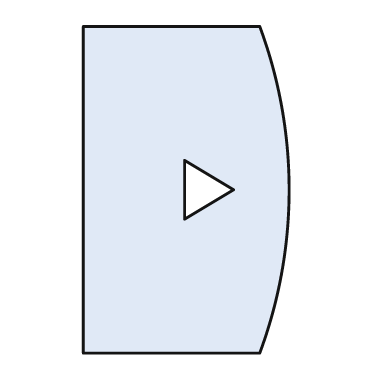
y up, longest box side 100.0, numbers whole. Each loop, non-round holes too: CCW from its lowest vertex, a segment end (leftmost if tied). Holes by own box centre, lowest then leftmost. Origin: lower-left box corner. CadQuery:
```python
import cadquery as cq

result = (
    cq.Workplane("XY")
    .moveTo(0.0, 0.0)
    .lineTo(54.0, 0.0)
    .threePointArc((63.0, 50.0), (54.0, 100.0))
    .lineTo(0.0, 100.0)
    .close()
    .moveTo(31.0, 41.0)
    .lineTo(46.0, 50.0)
    .lineTo(31.0, 59.0)
    .close()
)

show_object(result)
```